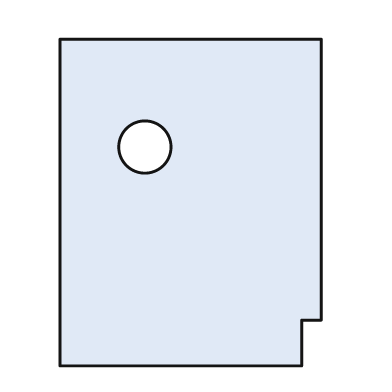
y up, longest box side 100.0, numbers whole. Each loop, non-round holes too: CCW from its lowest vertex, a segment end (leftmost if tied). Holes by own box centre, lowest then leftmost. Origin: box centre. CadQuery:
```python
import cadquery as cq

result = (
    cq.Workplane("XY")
    .moveTo(-40.0, -50.0)
    .lineTo(34.0, -50.0)
    .lineTo(34.0, -36.0)
    .lineTo(40.0, -36.0)
    .lineTo(40.0, 50.0)
    .lineTo(-40.0, 50.0)
    .close()
    .moveTo(-14.0, 17.0)
    .circle(8.0)
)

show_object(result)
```